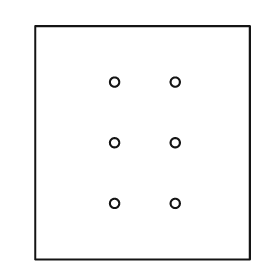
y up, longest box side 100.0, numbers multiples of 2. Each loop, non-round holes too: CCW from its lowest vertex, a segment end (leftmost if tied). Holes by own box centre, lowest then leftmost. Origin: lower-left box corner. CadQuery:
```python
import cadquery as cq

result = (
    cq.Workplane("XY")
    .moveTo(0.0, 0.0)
    .lineTo(92.0, 0.0)
    .lineTo(92.0, 100.0)
    .lineTo(0.0, 100.0)
    .close()
    .moveTo(34.0, 24.0)
    .circle(2.0)
    .moveTo(60.0, 24.0)
    .circle(2.0)
    .moveTo(34.0, 50.0)
    .circle(2.0)
    .moveTo(60.0, 50.0)
    .circle(2.0)
    .moveTo(34.0, 76.0)
    .circle(2.0)
    .moveTo(60.0, 76.0)
    .circle(2.0)
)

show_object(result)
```